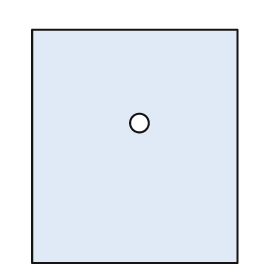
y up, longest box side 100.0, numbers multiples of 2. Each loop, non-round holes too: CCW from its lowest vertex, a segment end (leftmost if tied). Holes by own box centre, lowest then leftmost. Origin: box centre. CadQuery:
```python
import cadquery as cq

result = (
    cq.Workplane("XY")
    .moveTo(-44.0, -50.0)
    .lineTo(44.0, -50.0)
    .lineTo(44.0, 50.0)
    .lineTo(-44.0, 50.0)
    .close()
    .moveTo(2.0, 10.0)
    .circle(4.0)
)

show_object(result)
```